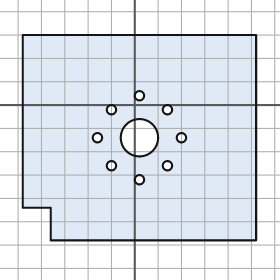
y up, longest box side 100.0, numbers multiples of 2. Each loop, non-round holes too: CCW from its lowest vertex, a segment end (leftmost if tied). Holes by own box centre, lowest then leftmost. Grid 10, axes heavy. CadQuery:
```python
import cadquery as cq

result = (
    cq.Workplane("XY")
    .moveTo(-36.0, -58.0)
    .lineTo(52.0, -58.0)
    .lineTo(52.0, 30.0)
    .lineTo(-48.0, 30.0)
    .lineTo(-48.0, -44.0)
    .lineTo(-36.0, -44.0)
    .close()
    .moveTo(2.0, -32.0)
    .circle(2.0)
    .moveTo(-10.0, -26.0)
    .circle(2.0)
    .moveTo(14.0, -26.0)
    .circle(2.0)
    .moveTo(-16.0, -14.0)
    .circle(2.0)
    .moveTo(2.0, -14.0)
    .circle(8.0)
    .moveTo(20.0, -14.0)
    .circle(2.0)
    .moveTo(-10.0, -2.0)
    .circle(2.0)
    .moveTo(14.0, -2.0)
    .circle(2.0)
    .moveTo(2.0, 4.0)
    .circle(2.0)
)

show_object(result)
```